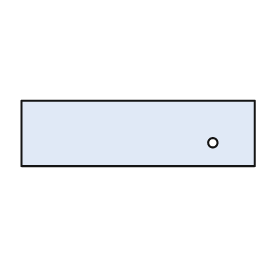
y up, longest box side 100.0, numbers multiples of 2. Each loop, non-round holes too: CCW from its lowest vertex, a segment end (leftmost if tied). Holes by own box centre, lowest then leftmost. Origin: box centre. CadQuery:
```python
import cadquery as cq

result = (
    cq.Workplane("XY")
    .moveTo(-50.0, -14.0)
    .lineTo(50.0, -14.0)
    .lineTo(50.0, 14.0)
    .lineTo(-50.0, 14.0)
    .close()
    .moveTo(32.0, -4.0)
    .circle(2.0)
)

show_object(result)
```